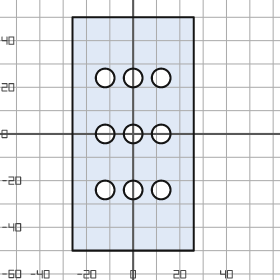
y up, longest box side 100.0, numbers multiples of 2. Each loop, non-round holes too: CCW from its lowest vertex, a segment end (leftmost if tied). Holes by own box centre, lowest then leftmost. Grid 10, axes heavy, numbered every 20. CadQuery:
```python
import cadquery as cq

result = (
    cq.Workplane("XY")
    .moveTo(-26.0, -50.0)
    .lineTo(26.0, -50.0)
    .lineTo(26.0, 50.0)
    .lineTo(-26.0, 50.0)
    .close()
    .moveTo(-12.0, -24.0)
    .circle(4.0)
    .moveTo(0.0, -24.0)
    .circle(4.0)
    .moveTo(12.0, -24.0)
    .circle(4.0)
    .moveTo(-12.0, 0.0)
    .circle(4.0)
    .moveTo(0.0, 0.0)
    .circle(4.0)
    .moveTo(12.0, 0.0)
    .circle(4.0)
    .moveTo(-12.0, 24.0)
    .circle(4.0)
    .moveTo(0.0, 24.0)
    .circle(4.0)
    .moveTo(12.0, 24.0)
    .circle(4.0)
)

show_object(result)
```